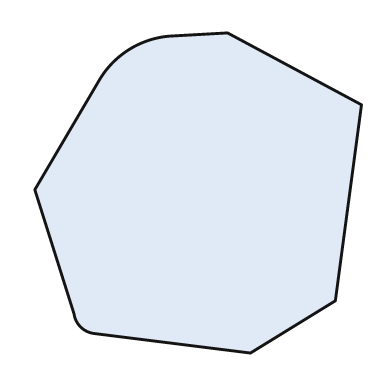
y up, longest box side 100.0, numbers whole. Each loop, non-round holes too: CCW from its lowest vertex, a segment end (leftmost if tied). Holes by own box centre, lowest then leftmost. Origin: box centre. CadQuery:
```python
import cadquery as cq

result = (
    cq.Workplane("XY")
    .moveTo(16.0, -49.0)
    .lineTo(42.0, -33.0)
    .lineTo(50.0, 27.0)
    .lineTo(9.0, 49.0)
    .lineTo(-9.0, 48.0)
    .threePointArc((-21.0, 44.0), (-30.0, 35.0))
    .lineTo(-50.0, 1.0)
    .lineTo(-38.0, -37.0)
    .threePointArc((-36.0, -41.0), (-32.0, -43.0))
    .close()
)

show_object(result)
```